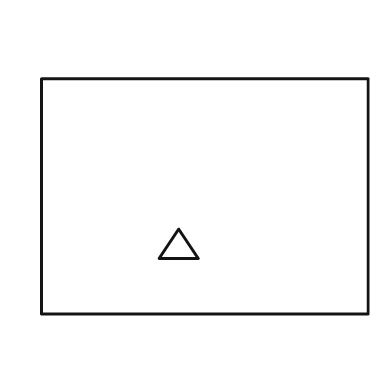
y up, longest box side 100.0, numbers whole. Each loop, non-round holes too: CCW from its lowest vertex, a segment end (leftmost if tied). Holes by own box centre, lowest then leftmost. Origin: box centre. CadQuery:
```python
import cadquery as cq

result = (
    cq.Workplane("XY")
    .moveTo(-50.0, -36.0)
    .lineTo(50.0, -36.0)
    .lineTo(50.0, 36.0)
    .lineTo(-50.0, 36.0)
    .close()
    .moveTo(-14.0, -19.0)
    .lineTo(-2.0, -19.0)
    .lineTo(-8.0, -10.0)
    .close()
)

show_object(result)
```